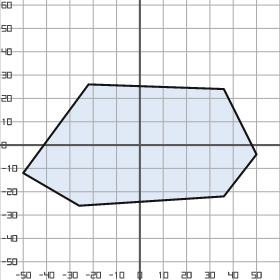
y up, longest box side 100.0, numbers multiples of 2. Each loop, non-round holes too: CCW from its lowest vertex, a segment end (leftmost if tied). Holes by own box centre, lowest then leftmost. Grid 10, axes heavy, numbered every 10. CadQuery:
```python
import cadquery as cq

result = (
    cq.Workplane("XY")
    .moveTo(-26.0, -26.0)
    .lineTo(36.0, -22.0)
    .lineTo(50.0, -4.0)
    .lineTo(36.0, 24.0)
    .lineTo(-22.0, 26.0)
    .lineTo(-50.0, -12.0)
    .close()
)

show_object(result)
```